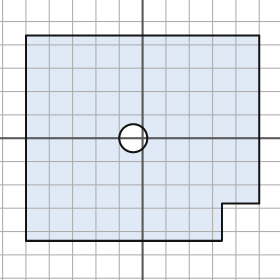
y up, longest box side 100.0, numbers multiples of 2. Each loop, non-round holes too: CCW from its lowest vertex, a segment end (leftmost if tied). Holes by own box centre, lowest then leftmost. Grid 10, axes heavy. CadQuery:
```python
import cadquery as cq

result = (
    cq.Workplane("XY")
    .moveTo(-50.0, -44.0)
    .lineTo(34.0, -44.0)
    .lineTo(34.0, -28.0)
    .lineTo(50.0, -28.0)
    .lineTo(50.0, 44.0)
    .lineTo(-50.0, 44.0)
    .close()
    .moveTo(-4.0, 0.0)
    .circle(6.0)
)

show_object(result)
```